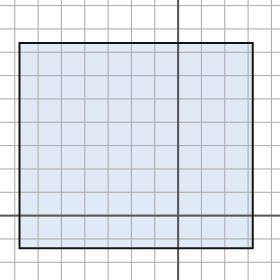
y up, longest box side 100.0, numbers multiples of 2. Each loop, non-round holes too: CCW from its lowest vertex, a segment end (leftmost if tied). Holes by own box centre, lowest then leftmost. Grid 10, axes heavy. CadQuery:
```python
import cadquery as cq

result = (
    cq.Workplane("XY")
    .moveTo(-68.0, -14.0)
    .lineTo(32.0, -14.0)
    .lineTo(32.0, 74.0)
    .lineTo(-68.0, 74.0)
    .close()
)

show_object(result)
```